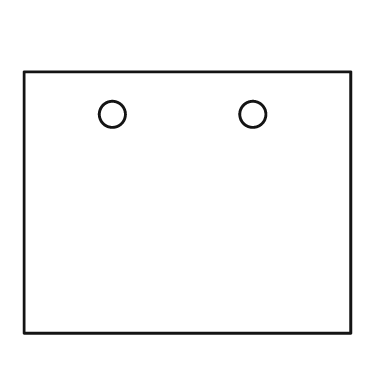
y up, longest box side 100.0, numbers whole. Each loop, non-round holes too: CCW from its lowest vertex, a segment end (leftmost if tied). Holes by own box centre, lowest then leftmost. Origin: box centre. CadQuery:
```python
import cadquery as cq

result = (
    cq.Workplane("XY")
    .moveTo(-50.0, -40.0)
    .lineTo(50.0, -40.0)
    .lineTo(50.0, 40.0)
    .lineTo(-50.0, 40.0)
    .close()
    .moveTo(-23.0, 27.0)
    .circle(4.0)
    .moveTo(20.0, 27.0)
    .circle(4.0)
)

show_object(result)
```